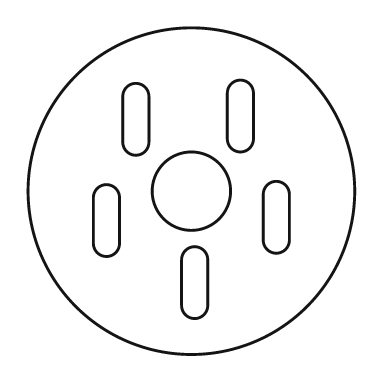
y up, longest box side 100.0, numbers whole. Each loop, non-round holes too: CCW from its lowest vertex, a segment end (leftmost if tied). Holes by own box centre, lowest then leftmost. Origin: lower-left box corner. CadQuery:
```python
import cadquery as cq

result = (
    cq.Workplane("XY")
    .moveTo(50.0, 50.0)
    .circle(50.0)
    .moveTo(47.0, 15.0)
    .threePointArc((51.0, 11.0), (55.0, 15.0))
    .lineTo(55.0, 29.0)
    .threePointArc((51.0, 33.0), (47.0, 29.0))
    .close()
    .moveTo(20.0, 34.0)
    .threePointArc((24.0, 30.0), (28.0, 34.0))
    .lineTo(28.0, 48.0)
    .threePointArc((24.0, 52.0), (20.0, 48.0))
    .close()
    .moveTo(72.0, 35.0)
    .threePointArc((76.0, 31.0), (80.0, 35.0))
    .lineTo(80.0, 49.0)
    .threePointArc((76.0, 53.0), (72.0, 49.0))
    .close()
    .moveTo(50.0, 50.0)
    .circle(12.0)
    .moveTo(29.0, 65.0)
    .threePointArc((33.0, 61.0), (37.0, 65.0))
    .lineTo(37.0, 79.0)
    .threePointArc((33.0, 83.0), (29.0, 79.0))
    .close()
    .moveTo(61.0, 66.0)
    .threePointArc((65.0, 62.0), (69.0, 66.0))
    .lineTo(69.0, 80.0)
    .threePointArc((65.0, 84.0), (61.0, 80.0))
    .close()
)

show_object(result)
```